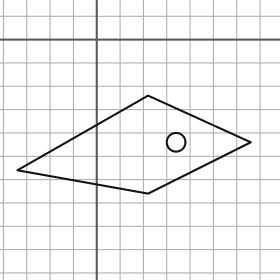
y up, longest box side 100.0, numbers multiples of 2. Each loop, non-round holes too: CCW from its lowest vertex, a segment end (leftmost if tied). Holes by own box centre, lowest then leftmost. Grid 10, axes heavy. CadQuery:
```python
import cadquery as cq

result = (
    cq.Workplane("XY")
    .moveTo(22.0, -66.0)
    .lineTo(66.0, -44.0)
    .lineTo(22.0, -24.0)
    .lineTo(-34.0, -56.0)
    .close()
    .moveTo(34.0, -44.0)
    .circle(4.0)
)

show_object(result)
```